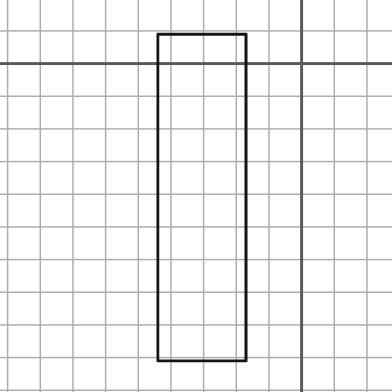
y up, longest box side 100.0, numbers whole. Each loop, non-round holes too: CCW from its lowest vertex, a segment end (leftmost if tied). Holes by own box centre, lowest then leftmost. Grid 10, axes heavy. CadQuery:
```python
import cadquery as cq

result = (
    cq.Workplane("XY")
    .moveTo(-44.0, -91.0)
    .lineTo(-17.0, -91.0)
    .lineTo(-17.0, 9.0)
    .lineTo(-44.0, 9.0)
    .close()
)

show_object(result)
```